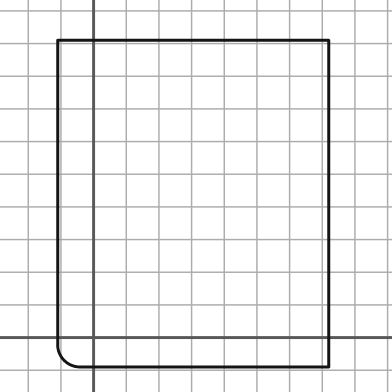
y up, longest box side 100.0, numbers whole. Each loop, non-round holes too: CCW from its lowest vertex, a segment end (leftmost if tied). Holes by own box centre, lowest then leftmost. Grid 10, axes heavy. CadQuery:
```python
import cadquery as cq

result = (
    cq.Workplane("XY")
    .moveTo(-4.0, -9.0)
    .lineTo(72.0, -9.0)
    .lineTo(72.0, 91.0)
    .lineTo(-11.0, 91.0)
    .lineTo(-11.0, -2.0)
    .threePointArc((-9.0, -7.0), (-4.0, -9.0))
    .close()
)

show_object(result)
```